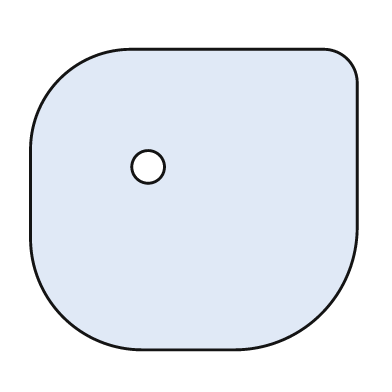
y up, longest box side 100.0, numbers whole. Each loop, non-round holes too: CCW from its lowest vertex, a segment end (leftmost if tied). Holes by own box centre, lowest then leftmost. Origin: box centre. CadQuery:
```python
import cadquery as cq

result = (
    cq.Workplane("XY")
    .moveTo(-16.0, -46.0)
    .lineTo(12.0, -46.0)
    .threePointArc((39.0, -35.0), (50.0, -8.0))
    .lineTo(50.0, 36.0)
    .threePointArc((47.0, 43.0), (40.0, 46.0))
    .lineTo(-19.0, 46.0)
    .threePointArc((-41.0, 37.0), (-50.0, 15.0))
    .lineTo(-50.0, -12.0)
    .threePointArc((-40.0, -36.0), (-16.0, -46.0))
    .close()
    .moveTo(-14.0, 10.0)
    .circle(5.0)
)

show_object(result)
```